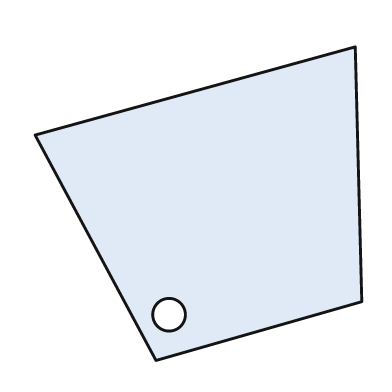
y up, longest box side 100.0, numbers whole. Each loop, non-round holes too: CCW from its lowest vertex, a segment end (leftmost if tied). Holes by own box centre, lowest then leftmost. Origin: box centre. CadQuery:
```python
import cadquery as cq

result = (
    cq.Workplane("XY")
    .moveTo(-13.0, -48.0)
    .lineTo(50.0, -30.0)
    .lineTo(48.0, 48.0)
    .lineTo(-50.0, 21.0)
    .close()
    .moveTo(-9.0, -34.0)
    .circle(5.0)
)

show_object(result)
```